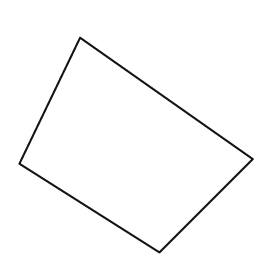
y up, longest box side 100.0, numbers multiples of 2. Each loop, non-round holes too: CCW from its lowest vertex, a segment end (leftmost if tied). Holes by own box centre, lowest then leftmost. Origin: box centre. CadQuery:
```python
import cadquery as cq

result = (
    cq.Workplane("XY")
    .moveTo(10.0, -46.0)
    .lineTo(50.0, -6.0)
    .lineTo(-24.0, 46.0)
    .lineTo(-50.0, -8.0)
    .close()
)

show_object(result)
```